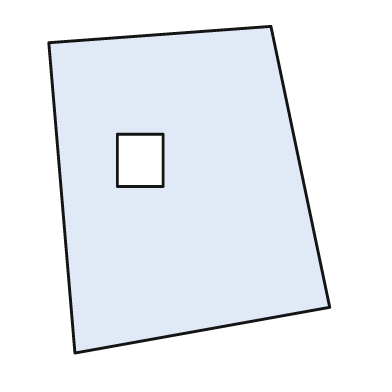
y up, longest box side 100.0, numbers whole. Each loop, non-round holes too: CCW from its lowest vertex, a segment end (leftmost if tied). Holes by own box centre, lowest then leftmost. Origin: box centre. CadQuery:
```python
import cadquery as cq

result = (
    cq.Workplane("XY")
    .moveTo(-35.0, -50.0)
    .lineTo(43.0, -36.0)
    .lineTo(25.0, 50.0)
    .lineTo(-43.0, 45.0)
    .close()
    .moveTo(-22.0, 1.0)
    .lineTo(-8.0, 1.0)
    .lineTo(-8.0, 17.0)
    .lineTo(-22.0, 17.0)
    .close()
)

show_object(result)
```